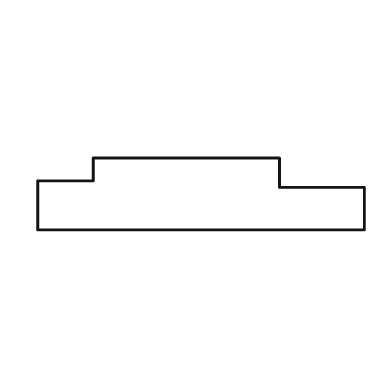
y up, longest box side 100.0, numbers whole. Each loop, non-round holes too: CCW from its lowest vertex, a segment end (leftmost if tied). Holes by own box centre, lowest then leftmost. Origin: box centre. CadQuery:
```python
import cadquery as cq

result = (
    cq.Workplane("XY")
    .moveTo(-50.0, -11.0)
    .lineTo(50.0, -11.0)
    .lineTo(50.0, 2.0)
    .lineTo(24.0, 2.0)
    .lineTo(24.0, 11.0)
    .lineTo(-33.0, 11.0)
    .lineTo(-33.0, 4.0)
    .lineTo(-50.0, 4.0)
    .close()
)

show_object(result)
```